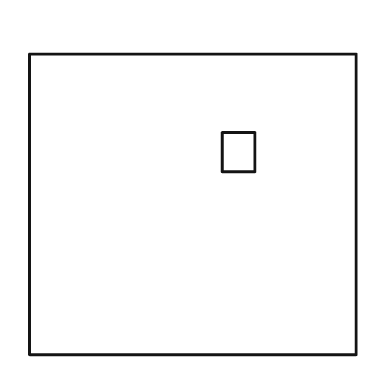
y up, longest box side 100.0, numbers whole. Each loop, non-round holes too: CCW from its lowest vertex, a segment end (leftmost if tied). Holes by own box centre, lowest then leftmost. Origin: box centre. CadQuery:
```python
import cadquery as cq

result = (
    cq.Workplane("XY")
    .moveTo(-50.0, -46.0)
    .lineTo(50.0, -46.0)
    .lineTo(50.0, 46.0)
    .lineTo(-50.0, 46.0)
    .close()
    .moveTo(9.0, 10.0)
    .lineTo(19.0, 10.0)
    .lineTo(19.0, 22.0)
    .lineTo(9.0, 22.0)
    .close()
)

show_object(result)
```